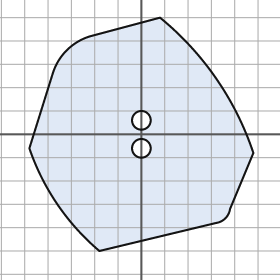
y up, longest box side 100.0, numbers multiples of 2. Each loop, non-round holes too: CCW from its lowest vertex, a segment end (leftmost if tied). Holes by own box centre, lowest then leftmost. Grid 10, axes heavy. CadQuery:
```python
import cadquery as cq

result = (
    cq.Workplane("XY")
    .moveTo(-18.0, -50.0)
    .lineTo(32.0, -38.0)
    .threePointArc((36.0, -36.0), (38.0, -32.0))
    .lineTo(48.0, -8.0)
    .threePointArc((32.0, 24.0), (8.0, 50.0))
    .lineTo(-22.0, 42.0)
    .threePointArc((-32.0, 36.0), (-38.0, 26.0))
    .lineTo(-48.0, -6.0)
    .threePointArc((-36.0, -30.0), (-18.0, -50.0))
    .close()
    .moveTo(0.0, -6.0)
    .circle(4.0)
    .moveTo(0.0, 6.0)
    .circle(4.0)
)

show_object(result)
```